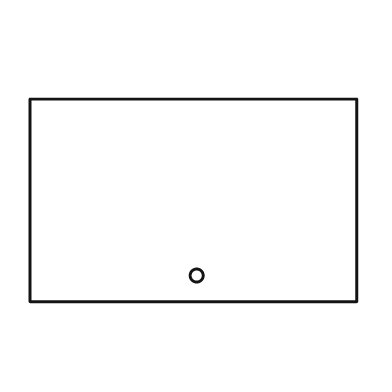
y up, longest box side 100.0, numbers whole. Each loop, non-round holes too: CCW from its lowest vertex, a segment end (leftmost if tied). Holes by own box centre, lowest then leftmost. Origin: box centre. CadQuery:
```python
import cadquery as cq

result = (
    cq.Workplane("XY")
    .moveTo(-50.0, -31.0)
    .lineTo(50.0, -31.0)
    .lineTo(50.0, 31.0)
    .lineTo(-50.0, 31.0)
    .close()
    .moveTo(1.0, -23.0)
    .circle(2.0)
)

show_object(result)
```